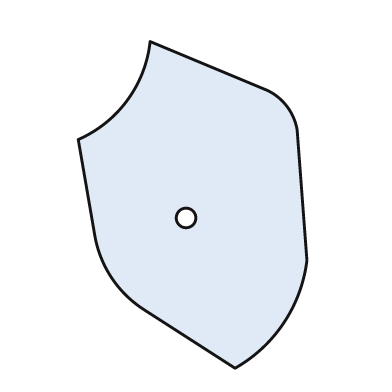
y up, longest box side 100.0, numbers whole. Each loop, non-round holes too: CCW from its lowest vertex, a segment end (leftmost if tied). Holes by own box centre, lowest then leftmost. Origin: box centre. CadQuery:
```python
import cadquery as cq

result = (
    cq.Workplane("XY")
    .moveTo(13.0, -50.0)
    .threePointArc((28.0, -36.0), (35.0, -17.0))
    .lineTo(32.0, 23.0)
    .threePointArc((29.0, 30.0), (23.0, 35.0))
    .lineTo(-13.0, 50.0)
    .threePointArc((-20.0, 32.0), (-35.0, 20.0))
    .lineTo(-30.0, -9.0)
    .threePointArc((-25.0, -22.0), (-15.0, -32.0))
    .close()
    .moveTo(-2.0, -4.0)
    .circle(3.0)
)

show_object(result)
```